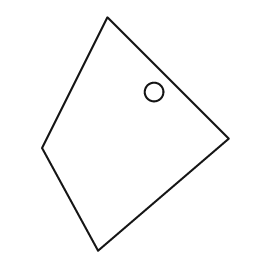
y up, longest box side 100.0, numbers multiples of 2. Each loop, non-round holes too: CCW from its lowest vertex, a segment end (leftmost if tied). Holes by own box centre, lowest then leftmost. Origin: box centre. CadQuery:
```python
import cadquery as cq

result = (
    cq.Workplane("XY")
    .moveTo(-16.0, -50.0)
    .lineTo(40.0, -2.0)
    .lineTo(-12.0, 50.0)
    .lineTo(-40.0, -6.0)
    .close()
    .moveTo(8.0, 18.0)
    .circle(4.0)
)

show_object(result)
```